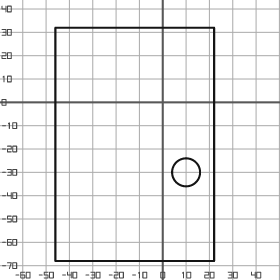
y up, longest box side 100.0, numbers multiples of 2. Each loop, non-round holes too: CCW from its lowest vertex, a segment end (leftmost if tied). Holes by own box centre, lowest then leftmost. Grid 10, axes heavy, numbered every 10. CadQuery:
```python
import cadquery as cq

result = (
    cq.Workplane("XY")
    .moveTo(-46.0, -68.0)
    .lineTo(22.0, -68.0)
    .lineTo(22.0, 32.0)
    .lineTo(-46.0, 32.0)
    .close()
    .moveTo(10.0, -30.0)
    .circle(6.0)
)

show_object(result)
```